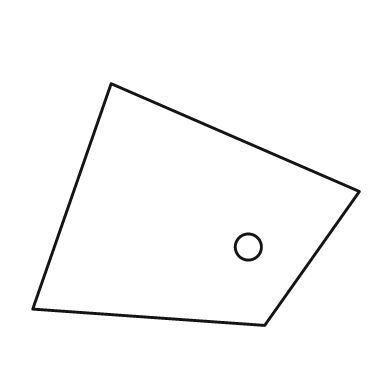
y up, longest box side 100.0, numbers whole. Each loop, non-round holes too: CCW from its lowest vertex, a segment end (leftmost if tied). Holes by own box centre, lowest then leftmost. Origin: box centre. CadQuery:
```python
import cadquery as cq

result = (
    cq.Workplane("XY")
    .moveTo(21.0, -37.0)
    .lineTo(50.0, 4.0)
    .lineTo(-26.0, 37.0)
    .lineTo(-50.0, -32.0)
    .close()
    .moveTo(16.0, -13.0)
    .circle(4.0)
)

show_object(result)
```